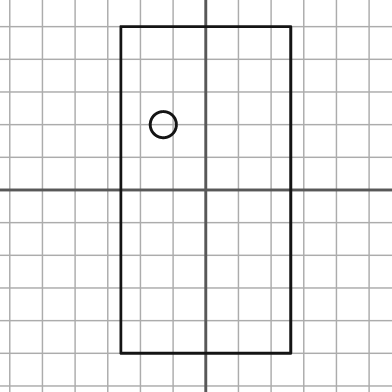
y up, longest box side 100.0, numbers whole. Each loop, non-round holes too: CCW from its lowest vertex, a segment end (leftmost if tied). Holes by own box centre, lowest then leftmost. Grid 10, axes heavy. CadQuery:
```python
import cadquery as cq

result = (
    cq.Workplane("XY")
    .moveTo(-26.0, -50.0)
    .lineTo(26.0, -50.0)
    .lineTo(26.0, 50.0)
    .lineTo(-26.0, 50.0)
    .close()
    .moveTo(-13.0, 20.0)
    .circle(4.0)
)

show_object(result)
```